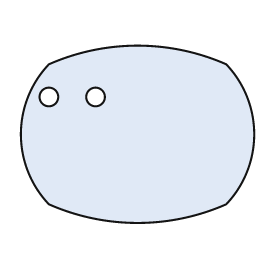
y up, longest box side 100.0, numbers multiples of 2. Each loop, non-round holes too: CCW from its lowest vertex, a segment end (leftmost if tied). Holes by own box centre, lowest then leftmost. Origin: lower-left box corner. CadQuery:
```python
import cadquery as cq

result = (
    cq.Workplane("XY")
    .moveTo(12.0, 8.0)
    .threePointArc((50.0, 0.0), (88.0, 8.0))
    .threePointArc((100.0, 38.0), (88.0, 68.0))
    .threePointArc((50.0, 76.0), (12.0, 68.0))
    .threePointArc((0.0, 38.0), (12.0, 8.0))
    .close()
    .moveTo(12.0, 54.0)
    .circle(4.0)
    .moveTo(32.0, 54.0)
    .circle(4.0)
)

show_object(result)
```